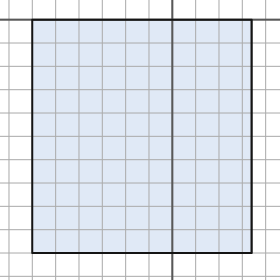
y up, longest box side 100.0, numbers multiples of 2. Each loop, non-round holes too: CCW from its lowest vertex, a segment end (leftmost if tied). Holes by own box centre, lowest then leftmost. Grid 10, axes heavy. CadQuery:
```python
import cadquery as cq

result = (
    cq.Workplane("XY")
    .moveTo(-60.0, -100.0)
    .lineTo(34.0, -100.0)
    .lineTo(34.0, 0.0)
    .lineTo(-60.0, 0.0)
    .close()
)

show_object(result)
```